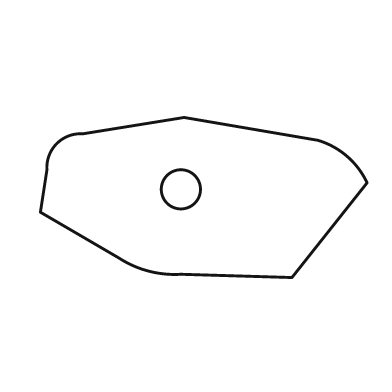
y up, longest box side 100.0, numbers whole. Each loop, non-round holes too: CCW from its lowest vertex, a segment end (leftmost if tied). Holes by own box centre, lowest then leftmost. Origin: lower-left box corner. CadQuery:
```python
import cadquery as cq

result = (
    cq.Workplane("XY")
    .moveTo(77.0, 0.0)
    .lineTo(100.0, 29.0)
    .threePointArc((94.0, 37.0), (85.0, 42.0))
    .lineTo(44.0, 49.0)
    .lineTo(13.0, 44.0)
    .threePointArc((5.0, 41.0), (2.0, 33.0))
    .lineTo(0.0, 20.0)
    .lineTo(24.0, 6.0)
    .threePointArc((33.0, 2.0), (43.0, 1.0))
    .close()
    .moveTo(43.0, 27.0)
    .circle(6.0)
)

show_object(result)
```